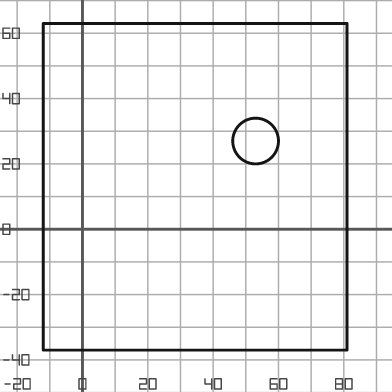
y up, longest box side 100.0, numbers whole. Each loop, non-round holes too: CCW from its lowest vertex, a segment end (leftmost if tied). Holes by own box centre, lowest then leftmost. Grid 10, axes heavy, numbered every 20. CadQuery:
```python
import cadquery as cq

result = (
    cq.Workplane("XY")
    .moveTo(-12.0, -37.0)
    .lineTo(81.0, -37.0)
    .lineTo(81.0, 63.0)
    .lineTo(-12.0, 63.0)
    .close()
    .moveTo(53.0, 27.0)
    .circle(7.0)
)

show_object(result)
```